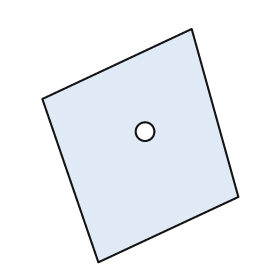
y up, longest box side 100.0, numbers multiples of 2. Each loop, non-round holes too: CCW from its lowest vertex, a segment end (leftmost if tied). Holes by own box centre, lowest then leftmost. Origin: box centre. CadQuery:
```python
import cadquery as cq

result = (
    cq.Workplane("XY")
    .moveTo(-18.0, -50.0)
    .lineTo(42.0, -22.0)
    .lineTo(22.0, 50.0)
    .lineTo(-42.0, 20.0)
    .close()
    .moveTo(2.0, 6.0)
    .circle(4.0)
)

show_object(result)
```